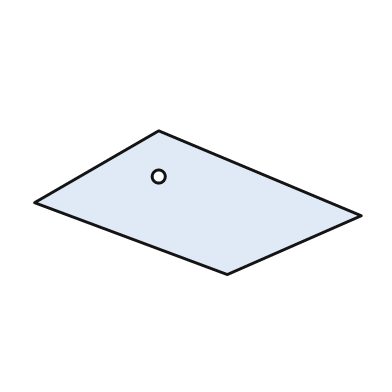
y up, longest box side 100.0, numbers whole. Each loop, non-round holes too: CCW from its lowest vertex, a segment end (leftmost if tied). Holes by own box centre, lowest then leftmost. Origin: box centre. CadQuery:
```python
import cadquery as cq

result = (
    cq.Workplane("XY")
    .moveTo(9.0, -22.0)
    .lineTo(50.0, -4.0)
    .lineTo(-12.0, 22.0)
    .lineTo(-50.0, 0.0)
    .close()
    .moveTo(-12.0, 8.0)
    .circle(2.0)
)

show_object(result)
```